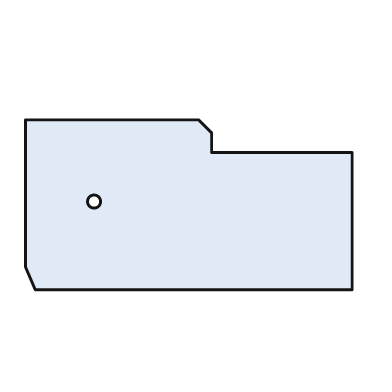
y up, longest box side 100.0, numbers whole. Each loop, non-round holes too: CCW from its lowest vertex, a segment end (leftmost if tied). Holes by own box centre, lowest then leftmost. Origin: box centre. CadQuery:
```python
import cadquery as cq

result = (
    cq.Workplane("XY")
    .moveTo(-47.0, -26.0)
    .lineTo(50.0, -26.0)
    .lineTo(50.0, 16.0)
    .lineTo(7.0, 16.0)
    .lineTo(7.0, 22.0)
    .lineTo(3.0, 26.0)
    .lineTo(-50.0, 26.0)
    .lineTo(-50.0, -19.0)
    .close()
    .moveTo(-29.0, 1.0)
    .circle(2.0)
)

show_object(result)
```